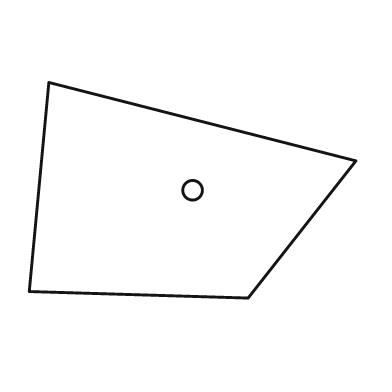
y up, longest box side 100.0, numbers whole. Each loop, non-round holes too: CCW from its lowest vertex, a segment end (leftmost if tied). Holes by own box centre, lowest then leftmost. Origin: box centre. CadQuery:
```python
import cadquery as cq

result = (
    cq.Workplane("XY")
    .moveTo(17.0, -33.0)
    .lineTo(50.0, 9.0)
    .lineTo(-44.0, 33.0)
    .lineTo(-50.0, -31.0)
    .close()
    .moveTo(0.0, 0.0)
    .circle(3.0)
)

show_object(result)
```